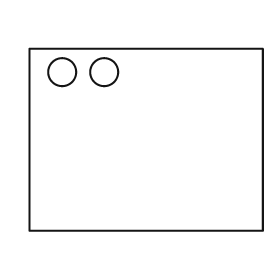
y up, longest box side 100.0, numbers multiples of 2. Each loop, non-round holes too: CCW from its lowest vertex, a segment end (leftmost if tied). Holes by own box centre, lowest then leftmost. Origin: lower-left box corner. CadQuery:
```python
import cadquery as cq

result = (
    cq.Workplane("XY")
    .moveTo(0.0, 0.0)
    .lineTo(100.0, 0.0)
    .lineTo(100.0, 78.0)
    .lineTo(0.0, 78.0)
    .close()
    .moveTo(14.0, 68.0)
    .circle(6.0)
    .moveTo(32.0, 68.0)
    .circle(6.0)
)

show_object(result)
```